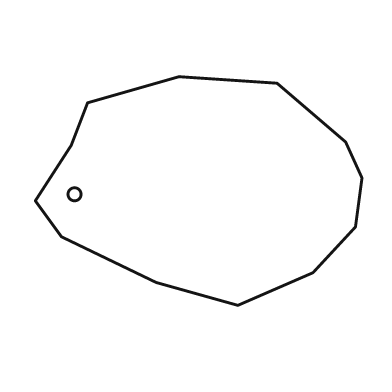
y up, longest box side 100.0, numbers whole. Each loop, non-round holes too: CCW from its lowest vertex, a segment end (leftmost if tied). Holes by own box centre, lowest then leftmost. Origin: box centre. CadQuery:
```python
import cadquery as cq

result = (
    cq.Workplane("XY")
    .moveTo(12.0, -35.0)
    .lineTo(35.0, -25.0)
    .lineTo(48.0, -11.0)
    .lineTo(50.0, 4.0)
    .lineTo(45.0, 15.0)
    .lineTo(24.0, 33.0)
    .lineTo(-6.0, 35.0)
    .lineTo(-34.0, 27.0)
    .lineTo(-39.0, 14.0)
    .lineTo(-50.0, -3.0)
    .lineTo(-42.0, -14.0)
    .lineTo(-13.0, -28.0)
    .close()
    .moveTo(-38.0, -1.0)
    .circle(2.0)
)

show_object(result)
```